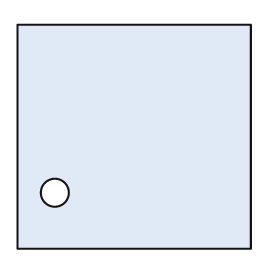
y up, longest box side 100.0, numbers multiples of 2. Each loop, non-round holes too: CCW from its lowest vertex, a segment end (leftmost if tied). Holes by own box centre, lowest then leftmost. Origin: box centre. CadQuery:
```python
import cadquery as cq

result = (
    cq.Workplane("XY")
    .moveTo(-50.0, -48.0)
    .lineTo(50.0, -48.0)
    .lineTo(50.0, 48.0)
    .lineTo(-50.0, 48.0)
    .close()
    .moveTo(-34.0, -24.0)
    .circle(6.0)
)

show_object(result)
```